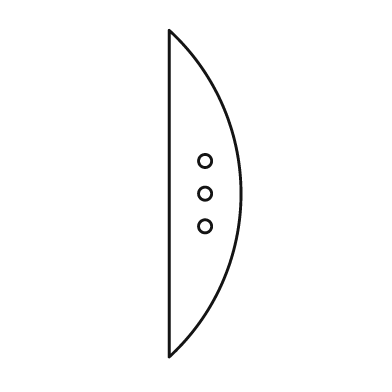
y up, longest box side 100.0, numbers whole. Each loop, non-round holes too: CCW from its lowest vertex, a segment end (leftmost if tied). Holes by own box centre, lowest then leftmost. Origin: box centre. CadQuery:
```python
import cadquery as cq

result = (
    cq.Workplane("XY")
    .moveTo(-11.0, -50.0)
    .threePointArc((11.0, 0.0), (-11.0, 50.0))
    .close()
    .moveTo(0.0, -10.0)
    .circle(2.0)
    .moveTo(0.0, 0.0)
    .circle(2.0)
    .moveTo(0.0, 10.0)
    .circle(2.0)
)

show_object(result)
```